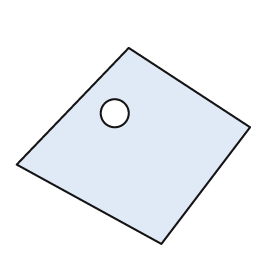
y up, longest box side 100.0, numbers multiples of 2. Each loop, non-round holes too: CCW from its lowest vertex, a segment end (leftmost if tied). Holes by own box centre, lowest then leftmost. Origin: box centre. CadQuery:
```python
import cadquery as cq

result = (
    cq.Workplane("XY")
    .moveTo(12.0, -42.0)
    .lineTo(50.0, 8.0)
    .lineTo(-2.0, 42.0)
    .lineTo(-50.0, -8.0)
    .close()
    .moveTo(-8.0, 14.0)
    .circle(6.0)
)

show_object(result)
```